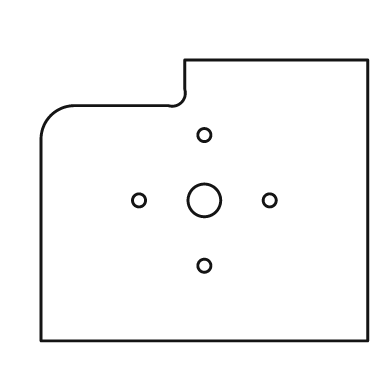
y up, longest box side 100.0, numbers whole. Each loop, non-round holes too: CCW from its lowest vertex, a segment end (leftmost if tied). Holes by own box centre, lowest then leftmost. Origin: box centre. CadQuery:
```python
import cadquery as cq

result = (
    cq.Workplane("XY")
    .moveTo(-50.0, -43.0)
    .lineTo(50.0, -43.0)
    .lineTo(50.0, 43.0)
    .lineTo(-6.0, 43.0)
    .lineTo(-6.0, 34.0)
    .threePointArc((-7.0, 30.0), (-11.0, 29.0))
    .lineTo(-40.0, 29.0)
    .threePointArc((-47.0, 26.0), (-50.0, 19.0))
    .close()
    .moveTo(0.0, -20.0)
    .circle(2.0)
    .moveTo(-20.0, 0.0)
    .circle(2.0)
    .moveTo(0.0, 0.0)
    .circle(5.0)
    .moveTo(20.0, 0.0)
    .circle(2.0)
    .moveTo(0.0, 20.0)
    .circle(2.0)
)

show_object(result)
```